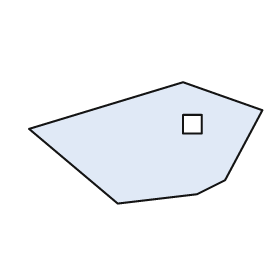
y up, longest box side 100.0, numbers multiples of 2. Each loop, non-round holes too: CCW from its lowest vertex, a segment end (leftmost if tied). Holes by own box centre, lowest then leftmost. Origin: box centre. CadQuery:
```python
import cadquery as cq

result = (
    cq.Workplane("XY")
    .moveTo(-12.0, -26.0)
    .lineTo(22.0, -22.0)
    .lineTo(34.0, -16.0)
    .lineTo(50.0, 14.0)
    .lineTo(16.0, 26.0)
    .lineTo(-50.0, 6.0)
    .close()
    .moveTo(16.0, 4.0)
    .lineTo(24.0, 4.0)
    .lineTo(24.0, 12.0)
    .lineTo(16.0, 12.0)
    .close()
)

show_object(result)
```